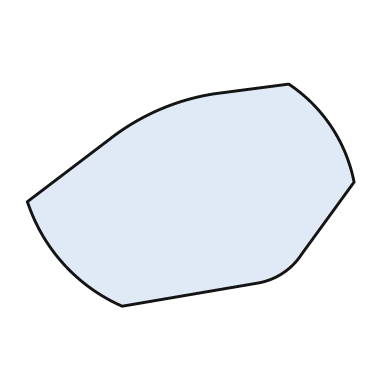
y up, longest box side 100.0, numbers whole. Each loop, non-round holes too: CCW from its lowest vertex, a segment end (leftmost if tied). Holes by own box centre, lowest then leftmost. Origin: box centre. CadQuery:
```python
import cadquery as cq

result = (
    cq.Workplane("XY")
    .moveTo(-21.0, -34.0)
    .lineTo(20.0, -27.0)
    .threePointArc((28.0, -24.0), (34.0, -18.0))
    .lineTo(50.0, 4.0)
    .threePointArc((43.0, 21.0), (30.0, 34.0))
    .lineTo(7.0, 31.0)
    .threePointArc((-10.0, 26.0), (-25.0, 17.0))
    .lineTo(-50.0, -2.0)
    .threePointArc((-39.0, -21.0), (-21.0, -34.0))
    .close()
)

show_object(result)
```